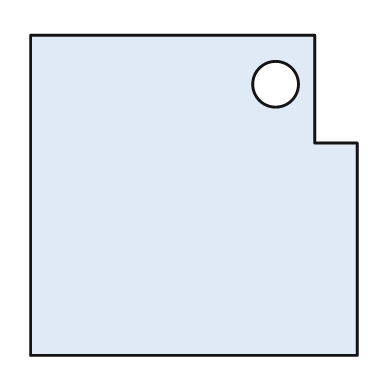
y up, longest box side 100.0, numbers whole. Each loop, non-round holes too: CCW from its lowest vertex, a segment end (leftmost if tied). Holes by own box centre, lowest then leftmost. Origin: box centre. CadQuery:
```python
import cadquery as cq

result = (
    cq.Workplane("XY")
    .moveTo(-50.0, -49.0)
    .lineTo(50.0, -49.0)
    .lineTo(50.0, 16.0)
    .lineTo(37.0, 16.0)
    .lineTo(37.0, 49.0)
    .lineTo(-50.0, 49.0)
    .close()
    .moveTo(25.0, 34.0)
    .circle(7.0)
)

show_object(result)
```